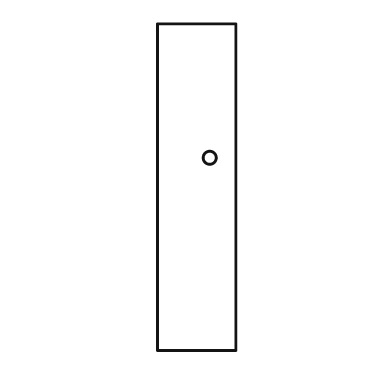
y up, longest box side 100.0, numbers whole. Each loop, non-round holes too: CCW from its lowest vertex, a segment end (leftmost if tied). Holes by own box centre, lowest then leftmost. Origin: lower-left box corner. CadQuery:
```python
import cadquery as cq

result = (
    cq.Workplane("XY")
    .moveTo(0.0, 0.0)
    .lineTo(24.0, 0.0)
    .lineTo(24.0, 100.0)
    .lineTo(0.0, 100.0)
    .close()
    .moveTo(16.0, 59.0)
    .circle(2.0)
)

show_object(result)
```